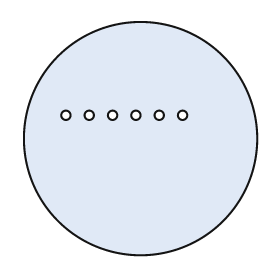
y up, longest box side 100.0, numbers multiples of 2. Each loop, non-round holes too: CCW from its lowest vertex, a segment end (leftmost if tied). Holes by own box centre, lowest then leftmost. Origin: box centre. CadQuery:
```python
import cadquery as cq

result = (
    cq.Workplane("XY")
    .moveTo(0.0, 0.0)
    .circle(50.0)
    .moveTo(-32.0, 10.0)
    .circle(2.0)
    .moveTo(-22.0, 10.0)
    .circle(2.0)
    .moveTo(-12.0, 10.0)
    .circle(2.0)
    .moveTo(-2.0, 10.0)
    .circle(2.0)
    .moveTo(8.0, 10.0)
    .circle(2.0)
    .moveTo(18.0, 10.0)
    .circle(2.0)
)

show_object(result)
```